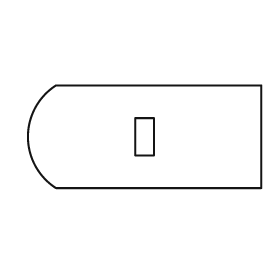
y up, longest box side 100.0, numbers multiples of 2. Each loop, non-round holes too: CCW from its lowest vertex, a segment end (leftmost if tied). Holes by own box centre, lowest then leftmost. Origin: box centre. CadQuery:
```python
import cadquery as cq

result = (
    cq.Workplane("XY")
    .moveTo(-38.0, -22.0)
    .lineTo(50.0, -22.0)
    .lineTo(50.0, 22.0)
    .lineTo(-38.0, 22.0)
    .threePointArc((-50.0, 0.0), (-38.0, -22.0))
    .close()
    .moveTo(-4.0, -8.0)
    .lineTo(4.0, -8.0)
    .lineTo(4.0, 8.0)
    .lineTo(-4.0, 8.0)
    .close()
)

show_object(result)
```